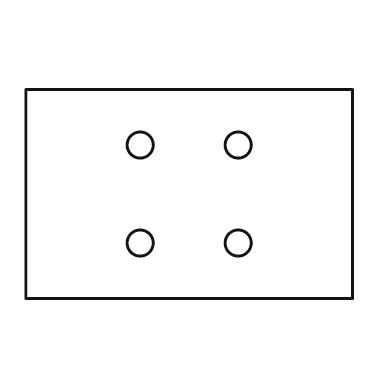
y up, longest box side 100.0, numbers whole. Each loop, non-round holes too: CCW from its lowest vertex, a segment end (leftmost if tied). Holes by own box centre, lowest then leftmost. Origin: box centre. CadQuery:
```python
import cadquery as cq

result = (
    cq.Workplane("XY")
    .moveTo(-50.0, -32.0)
    .lineTo(50.0, -32.0)
    .lineTo(50.0, 32.0)
    .lineTo(-50.0, 32.0)
    .close()
    .moveTo(-15.0, -15.0)
    .circle(4.0)
    .moveTo(15.0, -15.0)
    .circle(4.0)
    .moveTo(-15.0, 15.0)
    .circle(4.0)
    .moveTo(15.0, 15.0)
    .circle(4.0)
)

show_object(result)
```